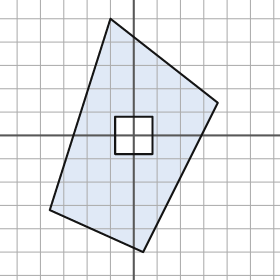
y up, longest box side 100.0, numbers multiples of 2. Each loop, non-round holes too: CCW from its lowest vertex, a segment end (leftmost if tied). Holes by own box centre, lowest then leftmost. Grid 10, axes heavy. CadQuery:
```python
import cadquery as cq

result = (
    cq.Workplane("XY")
    .moveTo(4.0, -50.0)
    .lineTo(36.0, 14.0)
    .lineTo(-10.0, 50.0)
    .lineTo(-36.0, -32.0)
    .close()
    .moveTo(-8.0, -8.0)
    .lineTo(8.0, -8.0)
    .lineTo(8.0, 8.0)
    .lineTo(-8.0, 8.0)
    .close()
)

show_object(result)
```